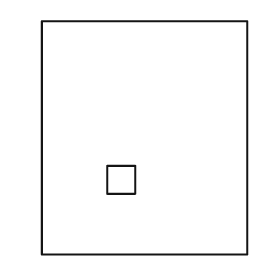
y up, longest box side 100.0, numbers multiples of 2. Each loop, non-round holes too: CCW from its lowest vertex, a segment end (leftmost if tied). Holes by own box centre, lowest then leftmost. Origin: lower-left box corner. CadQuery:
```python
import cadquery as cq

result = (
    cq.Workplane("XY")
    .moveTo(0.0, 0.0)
    .lineTo(88.0, 0.0)
    .lineTo(88.0, 100.0)
    .lineTo(0.0, 100.0)
    .close()
    .moveTo(28.0, 26.0)
    .lineTo(40.0, 26.0)
    .lineTo(40.0, 38.0)
    .lineTo(28.0, 38.0)
    .close()
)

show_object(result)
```